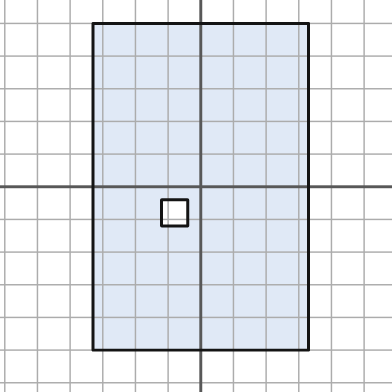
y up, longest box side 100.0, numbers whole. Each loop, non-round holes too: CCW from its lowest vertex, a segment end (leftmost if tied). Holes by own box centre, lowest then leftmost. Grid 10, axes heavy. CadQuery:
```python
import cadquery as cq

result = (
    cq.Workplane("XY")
    .moveTo(-33.0, -50.0)
    .lineTo(33.0, -50.0)
    .lineTo(33.0, 50.0)
    .lineTo(-33.0, 50.0)
    .close()
    .moveTo(-12.0, -12.0)
    .lineTo(-4.0, -12.0)
    .lineTo(-4.0, -4.0)
    .lineTo(-12.0, -4.0)
    .close()
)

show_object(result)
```